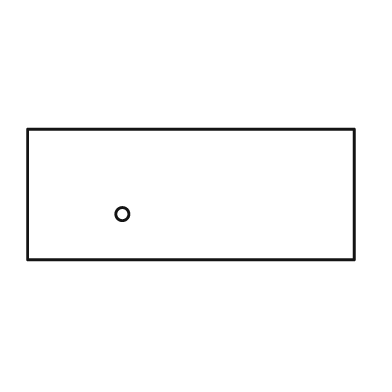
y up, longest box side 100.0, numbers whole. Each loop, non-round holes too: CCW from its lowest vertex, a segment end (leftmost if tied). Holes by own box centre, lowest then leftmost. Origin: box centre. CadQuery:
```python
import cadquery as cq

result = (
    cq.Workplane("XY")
    .moveTo(-50.0, -20.0)
    .lineTo(50.0, -20.0)
    .lineTo(50.0, 20.0)
    .lineTo(-50.0, 20.0)
    .close()
    .moveTo(-21.0, -6.0)
    .circle(2.0)
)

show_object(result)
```